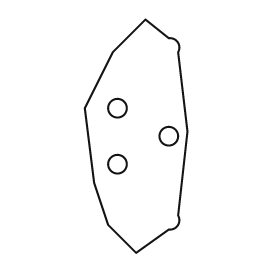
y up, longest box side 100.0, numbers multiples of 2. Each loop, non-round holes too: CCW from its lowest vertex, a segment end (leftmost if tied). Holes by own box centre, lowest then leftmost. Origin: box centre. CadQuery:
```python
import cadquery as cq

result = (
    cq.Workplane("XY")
    .moveTo(0.0, -50.0)
    .lineTo(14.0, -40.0)
    .threePointArc((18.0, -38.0), (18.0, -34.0))
    .lineTo(22.0, 2.0)
    .lineTo(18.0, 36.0)
    .threePointArc((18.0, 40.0), (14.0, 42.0))
    .lineTo(4.0, 50.0)
    .lineTo(-10.0, 36.0)
    .lineTo(-22.0, 12.0)
    .lineTo(-18.0, -20.0)
    .lineTo(-12.0, -38.0)
    .close()
    .moveTo(-8.0, -12.0)
    .circle(4.0)
    .moveTo(14.0, 0.0)
    .circle(4.0)
    .moveTo(-8.0, 12.0)
    .circle(4.0)
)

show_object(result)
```